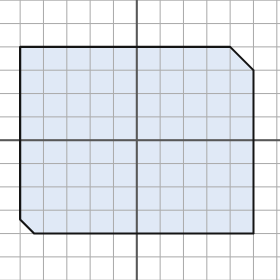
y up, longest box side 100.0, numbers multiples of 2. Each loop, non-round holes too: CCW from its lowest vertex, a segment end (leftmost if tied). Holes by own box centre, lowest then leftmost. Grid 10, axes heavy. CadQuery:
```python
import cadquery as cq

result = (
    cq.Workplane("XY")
    .moveTo(-44.0, -40.0)
    .lineTo(50.0, -40.0)
    .lineTo(50.0, 30.0)
    .lineTo(40.0, 40.0)
    .lineTo(-50.0, 40.0)
    .lineTo(-50.0, -34.0)
    .close()
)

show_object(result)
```